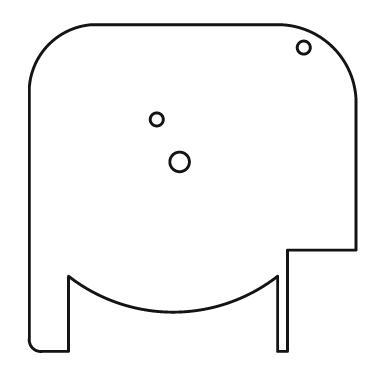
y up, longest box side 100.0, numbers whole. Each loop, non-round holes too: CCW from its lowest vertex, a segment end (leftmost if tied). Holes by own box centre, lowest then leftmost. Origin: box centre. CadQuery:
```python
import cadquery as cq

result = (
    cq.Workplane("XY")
    .moveTo(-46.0, -50.0)
    .lineTo(-38.0, -50.0)
    .lineTo(-38.0, -27.0)
    .threePointArc((-6.0, -38.0), (26.0, -27.0))
    .lineTo(26.0, -50.0)
    .lineTo(29.0, -50.0)
    .lineTo(29.0, -19.0)
    .lineTo(50.0, -19.0)
    .lineTo(50.0, 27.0)
    .threePointArc((43.0, 43.0), (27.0, 50.0))
    .lineTo(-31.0, 50.0)
    .threePointArc((-44.0, 44.0), (-50.0, 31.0))
    .lineTo(-50.0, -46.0)
    .threePointArc((-49.0, -49.0), (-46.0, -50.0))
    .close()
    .moveTo(-4.0, 8.0)
    .circle(3.0)
    .moveTo(-11.0, 21.0)
    .circle(2.0)
    .moveTo(34.0, 43.0)
    .circle(2.0)
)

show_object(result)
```